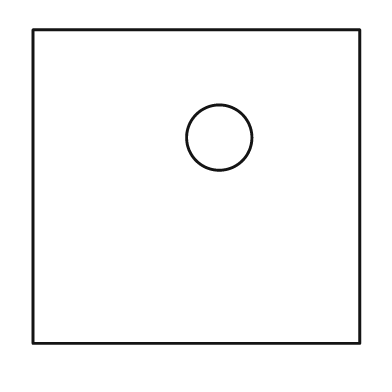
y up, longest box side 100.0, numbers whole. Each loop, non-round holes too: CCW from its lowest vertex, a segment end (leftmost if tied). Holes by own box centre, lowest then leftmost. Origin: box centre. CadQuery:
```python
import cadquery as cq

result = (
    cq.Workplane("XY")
    .moveTo(-50.0, -48.0)
    .lineTo(50.0, -48.0)
    .lineTo(50.0, 48.0)
    .lineTo(-50.0, 48.0)
    .close()
    .moveTo(7.0, 15.0)
    .circle(10.0)
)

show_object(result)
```